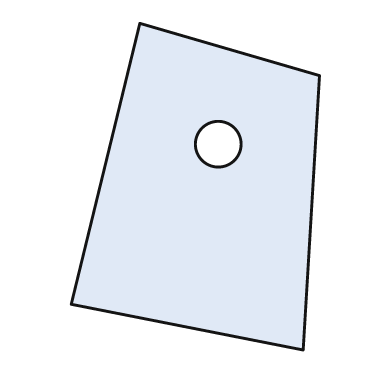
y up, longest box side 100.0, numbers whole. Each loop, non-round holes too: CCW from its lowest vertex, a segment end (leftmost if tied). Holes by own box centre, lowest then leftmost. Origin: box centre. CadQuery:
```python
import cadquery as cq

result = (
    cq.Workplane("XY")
    .moveTo(33.0, -50.0)
    .lineTo(38.0, 34.0)
    .lineTo(-17.0, 50.0)
    .lineTo(-38.0, -36.0)
    .close()
    .moveTo(7.0, 13.0)
    .circle(7.0)
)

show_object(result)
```